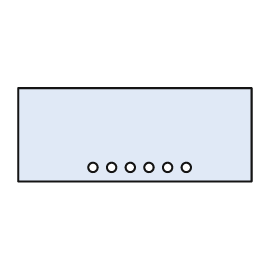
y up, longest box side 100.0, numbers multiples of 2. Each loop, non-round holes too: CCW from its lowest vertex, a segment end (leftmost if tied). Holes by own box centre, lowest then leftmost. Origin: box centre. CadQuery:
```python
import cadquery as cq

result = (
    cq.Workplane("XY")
    .moveTo(-50.0, -20.0)
    .lineTo(50.0, -20.0)
    .lineTo(50.0, 20.0)
    .lineTo(-50.0, 20.0)
    .close()
    .moveTo(-18.0, -14.0)
    .circle(2.0)
    .moveTo(-10.0, -14.0)
    .circle(2.0)
    .moveTo(-2.0, -14.0)
    .circle(2.0)
    .moveTo(6.0, -14.0)
    .circle(2.0)
    .moveTo(14.0, -14.0)
    .circle(2.0)
    .moveTo(22.0, -14.0)
    .circle(2.0)
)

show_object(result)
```